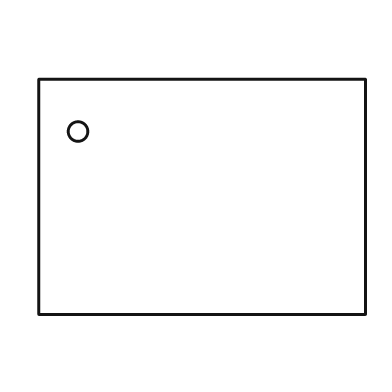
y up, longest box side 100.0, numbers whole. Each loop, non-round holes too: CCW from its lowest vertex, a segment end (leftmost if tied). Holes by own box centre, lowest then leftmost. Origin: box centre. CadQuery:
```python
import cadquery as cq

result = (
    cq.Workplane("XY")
    .moveTo(-50.0, -36.0)
    .lineTo(50.0, -36.0)
    .lineTo(50.0, 36.0)
    .lineTo(-50.0, 36.0)
    .close()
    .moveTo(-38.0, 20.0)
    .circle(3.0)
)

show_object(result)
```